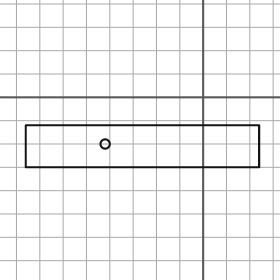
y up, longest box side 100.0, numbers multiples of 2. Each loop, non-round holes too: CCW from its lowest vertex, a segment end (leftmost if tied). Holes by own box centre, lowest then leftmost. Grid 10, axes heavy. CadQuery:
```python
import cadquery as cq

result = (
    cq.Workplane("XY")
    .moveTo(-76.0, -30.0)
    .lineTo(24.0, -30.0)
    .lineTo(24.0, -12.0)
    .lineTo(-76.0, -12.0)
    .close()
    .moveTo(-42.0, -20.0)
    .circle(2.0)
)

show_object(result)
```